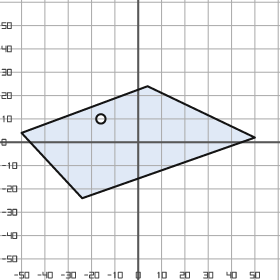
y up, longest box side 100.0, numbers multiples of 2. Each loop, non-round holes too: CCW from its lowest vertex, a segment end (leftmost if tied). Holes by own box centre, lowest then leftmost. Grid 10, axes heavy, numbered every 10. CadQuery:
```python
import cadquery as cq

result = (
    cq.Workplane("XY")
    .moveTo(-24.0, -24.0)
    .lineTo(50.0, 2.0)
    .lineTo(4.0, 24.0)
    .lineTo(-50.0, 4.0)
    .close()
    .moveTo(-16.0, 10.0)
    .circle(2.0)
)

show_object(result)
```